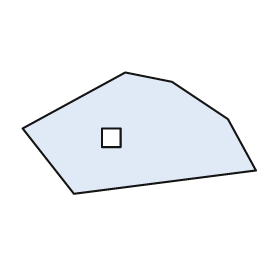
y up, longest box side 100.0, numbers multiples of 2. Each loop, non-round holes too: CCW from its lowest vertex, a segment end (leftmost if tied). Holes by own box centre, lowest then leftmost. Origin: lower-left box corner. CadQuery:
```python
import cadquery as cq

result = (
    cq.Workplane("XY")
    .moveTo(22.0, 0.0)
    .lineTo(100.0, 10.0)
    .lineTo(88.0, 32.0)
    .lineTo(64.0, 48.0)
    .lineTo(44.0, 52.0)
    .lineTo(0.0, 28.0)
    .close()
    .moveTo(34.0, 20.0)
    .lineTo(42.0, 20.0)
    .lineTo(42.0, 28.0)
    .lineTo(34.0, 28.0)
    .close()
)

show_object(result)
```